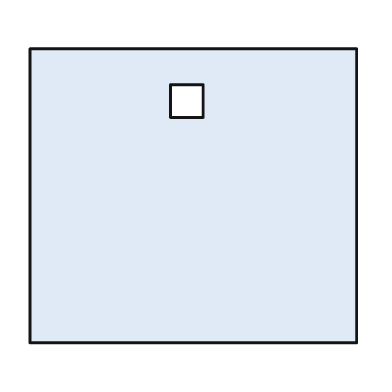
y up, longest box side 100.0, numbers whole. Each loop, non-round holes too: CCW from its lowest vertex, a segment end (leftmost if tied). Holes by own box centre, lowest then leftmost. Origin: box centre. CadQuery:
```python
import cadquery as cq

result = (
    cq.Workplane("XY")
    .moveTo(-50.0, -45.0)
    .lineTo(50.0, -45.0)
    .lineTo(50.0, 45.0)
    .lineTo(-50.0, 45.0)
    .close()
    .moveTo(-7.0, 24.0)
    .lineTo(3.0, 24.0)
    .lineTo(3.0, 34.0)
    .lineTo(-7.0, 34.0)
    .close()
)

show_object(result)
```